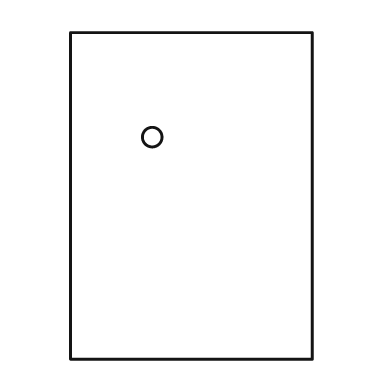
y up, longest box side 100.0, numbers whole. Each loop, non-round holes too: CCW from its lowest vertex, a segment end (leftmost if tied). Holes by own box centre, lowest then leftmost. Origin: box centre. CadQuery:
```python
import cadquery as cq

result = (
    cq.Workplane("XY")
    .moveTo(-37.0, -50.0)
    .lineTo(37.0, -50.0)
    .lineTo(37.0, 50.0)
    .lineTo(-37.0, 50.0)
    .close()
    .moveTo(-12.0, 18.0)
    .circle(3.0)
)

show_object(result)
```